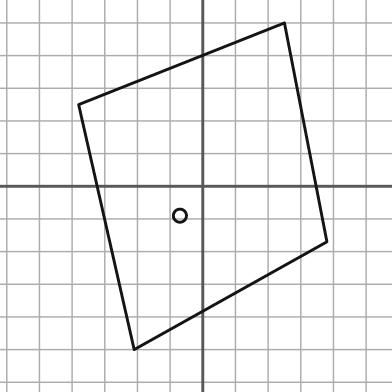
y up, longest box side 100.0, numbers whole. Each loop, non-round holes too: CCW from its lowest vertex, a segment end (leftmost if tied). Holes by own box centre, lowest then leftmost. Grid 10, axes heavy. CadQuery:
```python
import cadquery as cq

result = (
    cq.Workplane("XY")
    .moveTo(-21.0, -50.0)
    .lineTo(38.0, -17.0)
    .lineTo(25.0, 50.0)
    .lineTo(-38.0, 25.0)
    .close()
    .moveTo(-7.0, -9.0)
    .circle(2.0)
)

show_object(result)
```